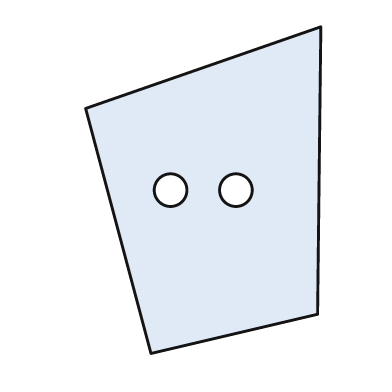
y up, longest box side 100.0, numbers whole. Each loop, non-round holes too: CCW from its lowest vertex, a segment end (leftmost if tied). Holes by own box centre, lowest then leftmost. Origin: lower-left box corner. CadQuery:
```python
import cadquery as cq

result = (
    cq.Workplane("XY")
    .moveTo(20.0, 0.0)
    .lineTo(71.0, 12.0)
    .lineTo(72.0, 100.0)
    .lineTo(0.0, 75.0)
    .close()
    .moveTo(26.0, 50.0)
    .circle(5.0)
    .moveTo(46.0, 50.0)
    .circle(5.0)
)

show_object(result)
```